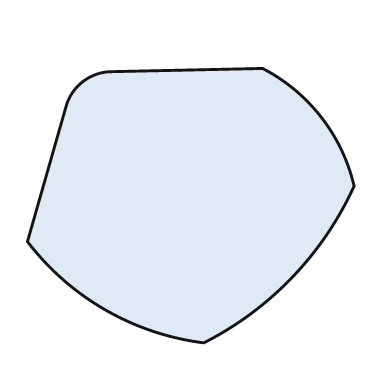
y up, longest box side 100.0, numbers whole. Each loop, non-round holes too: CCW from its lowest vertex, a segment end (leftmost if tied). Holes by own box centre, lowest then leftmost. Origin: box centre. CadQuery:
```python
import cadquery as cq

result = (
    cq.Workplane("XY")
    .moveTo(4.0, -42.0)
    .threePointArc((31.0, -22.0), (50.0, 6.0))
    .threePointArc((40.0, 27.0), (22.0, 42.0))
    .lineTo(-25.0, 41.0)
    .threePointArc((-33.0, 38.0), (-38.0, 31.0))
    .lineTo(-50.0, -11.0)
    .threePointArc((-26.0, -32.0), (4.0, -42.0))
    .close()
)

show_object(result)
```